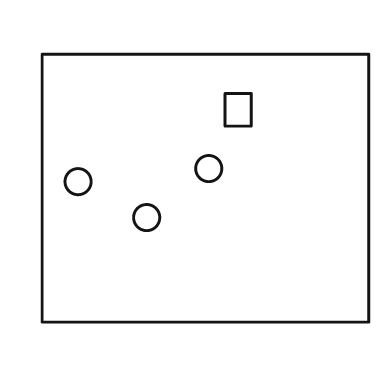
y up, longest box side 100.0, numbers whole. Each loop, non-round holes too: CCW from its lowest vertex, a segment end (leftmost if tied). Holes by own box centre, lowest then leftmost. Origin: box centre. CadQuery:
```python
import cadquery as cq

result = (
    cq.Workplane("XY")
    .moveTo(-50.0, -41.0)
    .lineTo(50.0, -41.0)
    .lineTo(50.0, 41.0)
    .lineTo(-50.0, 41.0)
    .close()
    .moveTo(-18.0, -9.0)
    .circle(4.0)
    .moveTo(-39.0, 2.0)
    .circle(4.0)
    .moveTo(1.0, 6.0)
    .circle(4.0)
    .moveTo(6.0, 19.0)
    .lineTo(14.0, 19.0)
    .lineTo(14.0, 29.0)
    .lineTo(6.0, 29.0)
    .close()
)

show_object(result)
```